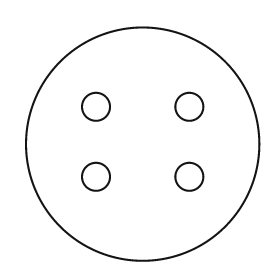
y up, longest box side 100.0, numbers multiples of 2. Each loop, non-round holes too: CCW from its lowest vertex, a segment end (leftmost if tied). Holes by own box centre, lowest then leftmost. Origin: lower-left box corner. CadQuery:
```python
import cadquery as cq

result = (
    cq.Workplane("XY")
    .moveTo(50.0, 50.0)
    .circle(50.0)
    .moveTo(30.0, 36.0)
    .circle(6.0)
    .moveTo(70.0, 36.0)
    .circle(6.0)
    .moveTo(30.0, 66.0)
    .circle(6.0)
    .moveTo(70.0, 66.0)
    .circle(6.0)
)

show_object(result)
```